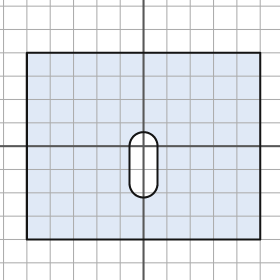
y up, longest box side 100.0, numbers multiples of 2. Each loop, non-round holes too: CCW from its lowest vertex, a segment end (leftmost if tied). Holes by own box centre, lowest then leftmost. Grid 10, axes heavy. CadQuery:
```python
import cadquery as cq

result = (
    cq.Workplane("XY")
    .moveTo(-50.0, -40.0)
    .lineTo(50.0, -40.0)
    .lineTo(50.0, 40.0)
    .lineTo(-50.0, 40.0)
    .close()
    .moveTo(-6.0, -16.0)
    .threePointArc((0.0, -22.0), (6.0, -16.0))
    .lineTo(6.0, 0.0)
    .threePointArc((0.0, 6.0), (-6.0, 0.0))
    .close()
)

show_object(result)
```